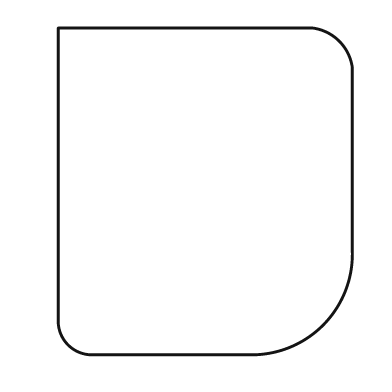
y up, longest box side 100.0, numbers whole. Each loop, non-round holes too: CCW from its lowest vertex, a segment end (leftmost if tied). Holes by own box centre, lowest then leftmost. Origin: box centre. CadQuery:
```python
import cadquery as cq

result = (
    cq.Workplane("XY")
    .moveTo(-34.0, -50.0)
    .lineTo(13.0, -50.0)
    .threePointArc((36.0, -41.0), (45.0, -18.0))
    .lineTo(45.0, 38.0)
    .threePointArc((41.0, 46.0), (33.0, 50.0))
    .lineTo(-45.0, 50.0)
    .lineTo(-45.0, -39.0)
    .threePointArc((-42.0, -47.0), (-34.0, -50.0))
    .close()
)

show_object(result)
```